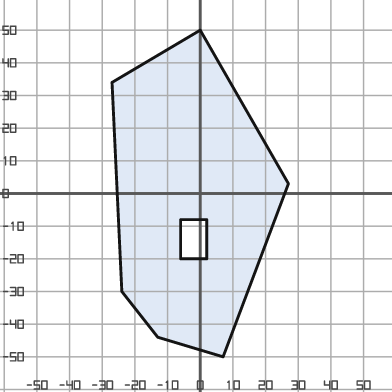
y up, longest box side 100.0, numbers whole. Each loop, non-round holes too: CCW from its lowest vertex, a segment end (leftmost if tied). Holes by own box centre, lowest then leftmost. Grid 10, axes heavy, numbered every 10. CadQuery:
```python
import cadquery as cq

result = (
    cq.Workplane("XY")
    .moveTo(7.0, -50.0)
    .lineTo(27.0, 3.0)
    .lineTo(0.0, 50.0)
    .lineTo(-27.0, 34.0)
    .lineTo(-24.0, -30.0)
    .lineTo(-13.0, -44.0)
    .close()
    .moveTo(-6.0, -20.0)
    .lineTo(2.0, -20.0)
    .lineTo(2.0, -8.0)
    .lineTo(-6.0, -8.0)
    .close()
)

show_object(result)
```